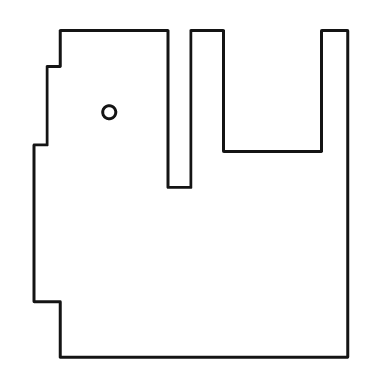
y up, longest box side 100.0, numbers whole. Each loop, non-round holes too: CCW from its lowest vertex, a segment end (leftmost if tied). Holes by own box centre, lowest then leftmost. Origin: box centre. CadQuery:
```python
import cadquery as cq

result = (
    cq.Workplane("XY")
    .moveTo(-40.0, -50.0)
    .lineTo(48.0, -50.0)
    .lineTo(48.0, 50.0)
    .lineTo(40.0, 50.0)
    .lineTo(40.0, 13.0)
    .lineTo(10.0, 13.0)
    .lineTo(10.0, 50.0)
    .lineTo(0.0, 50.0)
    .lineTo(0.0, 2.0)
    .lineTo(-7.0, 2.0)
    .lineTo(-7.0, 50.0)
    .lineTo(-40.0, 50.0)
    .lineTo(-40.0, 39.0)
    .lineTo(-44.0, 39.0)
    .lineTo(-44.0, 15.0)
    .lineTo(-48.0, 15.0)
    .lineTo(-48.0, -33.0)
    .lineTo(-40.0, -33.0)
    .close()
    .moveTo(-25.0, 25.0)
    .circle(2.0)
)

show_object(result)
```